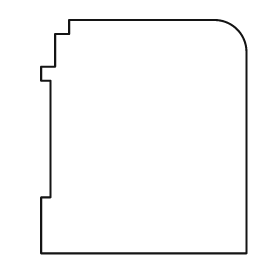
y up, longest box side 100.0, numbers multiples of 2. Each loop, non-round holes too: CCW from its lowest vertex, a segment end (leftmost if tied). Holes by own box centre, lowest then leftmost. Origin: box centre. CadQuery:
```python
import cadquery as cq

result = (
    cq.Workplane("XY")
    .moveTo(-44.0, -50.0)
    .lineTo(44.0, -50.0)
    .lineTo(44.0, 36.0)
    .threePointArc((40.0, 46.0), (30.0, 50.0))
    .lineTo(-32.0, 50.0)
    .lineTo(-32.0, 44.0)
    .lineTo(-38.0, 44.0)
    .lineTo(-38.0, 30.0)
    .lineTo(-44.0, 30.0)
    .lineTo(-44.0, 24.0)
    .lineTo(-40.0, 24.0)
    .lineTo(-40.0, -26.0)
    .lineTo(-44.0, -26.0)
    .close()
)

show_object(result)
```